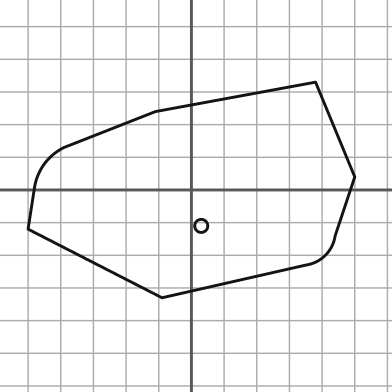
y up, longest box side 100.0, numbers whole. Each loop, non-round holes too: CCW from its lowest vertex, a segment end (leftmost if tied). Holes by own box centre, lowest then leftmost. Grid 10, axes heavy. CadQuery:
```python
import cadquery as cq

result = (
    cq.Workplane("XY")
    .moveTo(-9.0, -33.0)
    .lineTo(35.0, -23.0)
    .threePointArc((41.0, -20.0), (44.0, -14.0))
    .lineTo(50.0, 4.0)
    .lineTo(38.0, 33.0)
    .lineTo(-11.0, 24.0)
    .lineTo(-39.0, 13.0)
    .threePointArc((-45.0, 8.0), (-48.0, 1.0))
    .lineTo(-50.0, -12.0)
    .close()
    .moveTo(3.0, -11.0)
    .circle(2.0)
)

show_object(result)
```